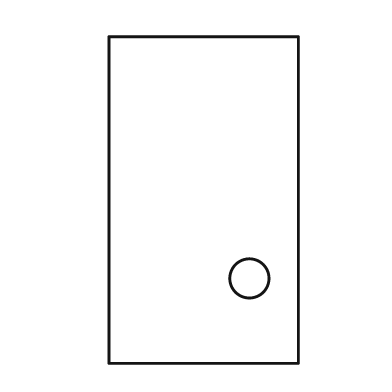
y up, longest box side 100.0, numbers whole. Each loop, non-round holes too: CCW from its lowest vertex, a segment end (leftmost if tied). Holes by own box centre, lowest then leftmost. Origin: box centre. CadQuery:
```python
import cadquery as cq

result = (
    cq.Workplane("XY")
    .moveTo(-29.0, -50.0)
    .lineTo(29.0, -50.0)
    .lineTo(29.0, 50.0)
    .lineTo(-29.0, 50.0)
    .close()
    .moveTo(14.0, -24.0)
    .circle(6.0)
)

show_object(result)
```